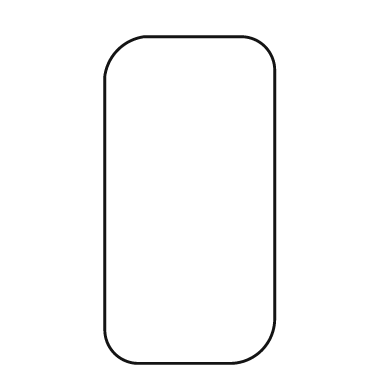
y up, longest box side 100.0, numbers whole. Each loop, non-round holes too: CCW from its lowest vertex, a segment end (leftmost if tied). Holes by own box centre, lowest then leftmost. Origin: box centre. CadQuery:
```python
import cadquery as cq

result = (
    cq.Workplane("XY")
    .moveTo(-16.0, -50.0)
    .lineTo(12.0, -50.0)
    .threePointArc((22.0, -46.0), (26.0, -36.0))
    .lineTo(26.0, 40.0)
    .threePointArc((23.0, 47.0), (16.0, 50.0))
    .lineTo(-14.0, 50.0)
    .threePointArc((-22.0, 46.0), (-26.0, 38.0))
    .lineTo(-26.0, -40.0)
    .threePointArc((-23.0, -47.0), (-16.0, -50.0))
    .close()
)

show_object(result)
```